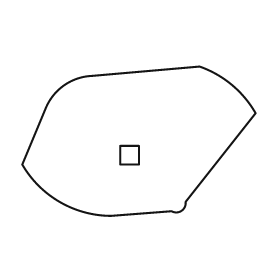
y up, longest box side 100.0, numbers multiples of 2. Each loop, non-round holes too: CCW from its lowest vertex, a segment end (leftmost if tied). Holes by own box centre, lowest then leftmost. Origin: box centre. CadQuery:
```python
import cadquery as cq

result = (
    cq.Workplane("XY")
    .moveTo(-12.0, -32.0)
    .lineTo(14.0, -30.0)
    .threePointArc((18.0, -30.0), (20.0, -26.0))
    .lineTo(50.0, 12.0)
    .threePointArc((40.0, 24.0), (26.0, 32.0))
    .lineTo(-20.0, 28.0)
    .threePointArc((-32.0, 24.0), (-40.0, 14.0))
    .lineTo(-50.0, -10.0)
    .threePointArc((-34.0, -26.0), (-12.0, -32.0))
    .close()
    .moveTo(-8.0, -10.0)
    .lineTo(0.0, -10.0)
    .lineTo(0.0, -2.0)
    .lineTo(-8.0, -2.0)
    .close()
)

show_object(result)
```